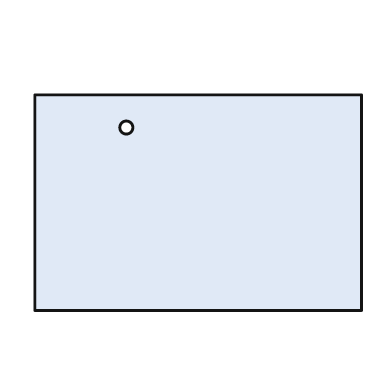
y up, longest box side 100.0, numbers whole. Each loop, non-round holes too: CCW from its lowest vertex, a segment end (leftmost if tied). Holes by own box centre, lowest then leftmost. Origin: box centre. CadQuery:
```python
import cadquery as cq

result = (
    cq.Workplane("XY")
    .moveTo(-50.0, -33.0)
    .lineTo(50.0, -33.0)
    .lineTo(50.0, 33.0)
    .lineTo(-50.0, 33.0)
    .close()
    .moveTo(-22.0, 23.0)
    .circle(2.0)
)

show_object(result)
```